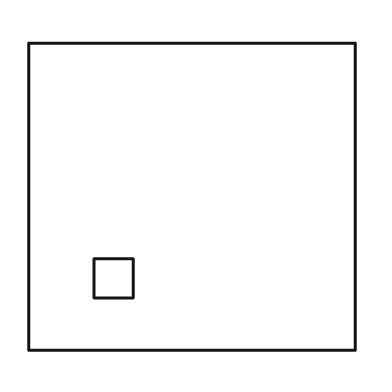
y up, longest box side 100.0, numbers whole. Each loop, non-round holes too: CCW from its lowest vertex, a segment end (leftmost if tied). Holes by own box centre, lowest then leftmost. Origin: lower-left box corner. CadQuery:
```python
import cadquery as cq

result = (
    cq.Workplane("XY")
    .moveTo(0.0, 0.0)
    .lineTo(100.0, 0.0)
    .lineTo(100.0, 94.0)
    .lineTo(0.0, 94.0)
    .close()
    .moveTo(20.0, 16.0)
    .lineTo(32.0, 16.0)
    .lineTo(32.0, 28.0)
    .lineTo(20.0, 28.0)
    .close()
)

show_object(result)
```